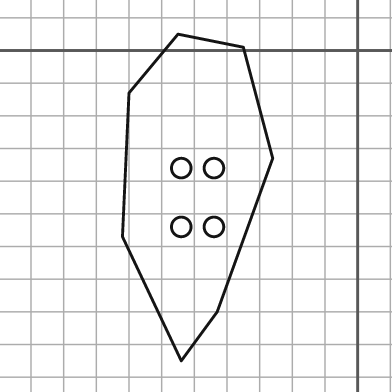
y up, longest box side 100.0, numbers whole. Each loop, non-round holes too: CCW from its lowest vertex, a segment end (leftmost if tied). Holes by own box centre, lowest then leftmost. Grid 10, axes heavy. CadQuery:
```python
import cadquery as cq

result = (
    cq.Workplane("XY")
    .moveTo(-54.0, -95.0)
    .lineTo(-43.0, -80.0)
    .lineTo(-26.0, -33.0)
    .lineTo(-35.0, 1.0)
    .lineTo(-55.0, 5.0)
    .lineTo(-70.0, -13.0)
    .lineTo(-72.0, -57.0)
    .close()
    .moveTo(-54.0, -54.0)
    .circle(3.0)
    .moveTo(-44.0, -54.0)
    .circle(3.0)
    .moveTo(-54.0, -36.0)
    .circle(3.0)
    .moveTo(-44.0, -36.0)
    .circle(3.0)
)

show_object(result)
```